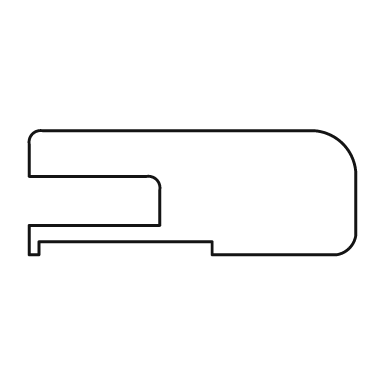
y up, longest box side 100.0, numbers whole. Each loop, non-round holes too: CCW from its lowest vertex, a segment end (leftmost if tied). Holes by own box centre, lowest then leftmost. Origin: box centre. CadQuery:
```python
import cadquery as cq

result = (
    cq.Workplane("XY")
    .moveTo(-50.0, -19.0)
    .lineTo(-47.0, -19.0)
    .lineTo(-47.0, -15.0)
    .lineTo(6.0, -15.0)
    .lineTo(6.0, -19.0)
    .lineTo(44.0, -19.0)
    .threePointArc((48.0, -17.0), (50.0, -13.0))
    .lineTo(50.0, 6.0)
    .threePointArc((46.0, 15.0), (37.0, 19.0))
    .lineTo(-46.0, 19.0)
    .threePointArc((-49.0, 18.0), (-50.0, 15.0))
    .lineTo(-50.0, 5.0)
    .lineTo(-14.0, 5.0)
    .threePointArc((-11.0, 4.0), (-10.0, 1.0))
    .lineTo(-10.0, -10.0)
    .lineTo(-50.0, -10.0)
    .close()
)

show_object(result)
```